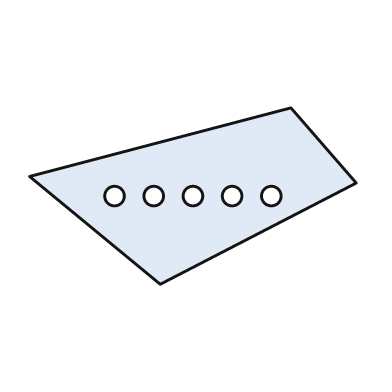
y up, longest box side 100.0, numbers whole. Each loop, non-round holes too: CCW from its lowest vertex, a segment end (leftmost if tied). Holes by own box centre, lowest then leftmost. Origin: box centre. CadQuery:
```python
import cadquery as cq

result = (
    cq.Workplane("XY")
    .moveTo(-10.0, -27.0)
    .lineTo(50.0, 4.0)
    .lineTo(30.0, 27.0)
    .lineTo(-50.0, 6.0)
    .close()
    .moveTo(-24.0, 0.0)
    .circle(3.0)
    .moveTo(-12.0, 0.0)
    .circle(3.0)
    .moveTo(0.0, 0.0)
    .circle(3.0)
    .moveTo(12.0, 0.0)
    .circle(3.0)
    .moveTo(24.0, 0.0)
    .circle(3.0)
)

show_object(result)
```